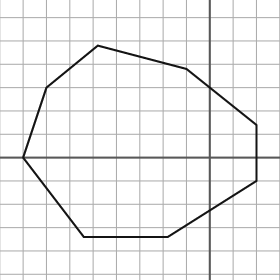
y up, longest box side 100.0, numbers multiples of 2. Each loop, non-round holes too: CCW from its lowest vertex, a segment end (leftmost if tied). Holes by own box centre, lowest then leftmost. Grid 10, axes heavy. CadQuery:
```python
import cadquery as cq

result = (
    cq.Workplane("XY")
    .moveTo(-54.0, -34.0)
    .lineTo(-18.0, -34.0)
    .lineTo(20.0, -10.0)
    .lineTo(20.0, 14.0)
    .lineTo(-10.0, 38.0)
    .lineTo(-48.0, 48.0)
    .lineTo(-70.0, 30.0)
    .lineTo(-80.0, 0.0)
    .close()
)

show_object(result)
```